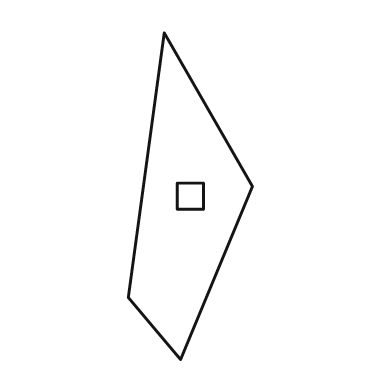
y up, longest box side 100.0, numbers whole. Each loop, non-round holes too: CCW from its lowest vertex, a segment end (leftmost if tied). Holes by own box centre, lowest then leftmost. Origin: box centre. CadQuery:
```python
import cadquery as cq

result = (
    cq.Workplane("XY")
    .moveTo(-3.0, -50.0)
    .lineTo(19.0, 3.0)
    .lineTo(-8.0, 50.0)
    .lineTo(-19.0, -31.0)
    .close()
    .moveTo(-4.0, -4.0)
    .lineTo(4.0, -4.0)
    .lineTo(4.0, 4.0)
    .lineTo(-4.0, 4.0)
    .close()
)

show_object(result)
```